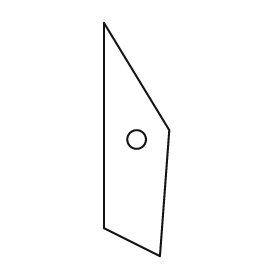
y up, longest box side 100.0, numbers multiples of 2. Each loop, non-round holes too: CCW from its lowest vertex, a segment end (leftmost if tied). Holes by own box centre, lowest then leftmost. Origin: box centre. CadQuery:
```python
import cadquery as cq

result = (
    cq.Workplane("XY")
    .moveTo(10.0, -50.0)
    .lineTo(14.0, 4.0)
    .lineTo(-14.0, 50.0)
    .lineTo(-14.0, -38.0)
    .close()
    .moveTo(0.0, 0.0)
    .circle(4.0)
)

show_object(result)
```